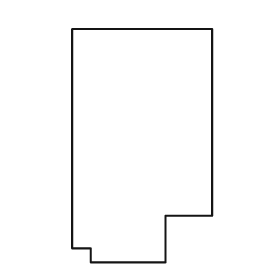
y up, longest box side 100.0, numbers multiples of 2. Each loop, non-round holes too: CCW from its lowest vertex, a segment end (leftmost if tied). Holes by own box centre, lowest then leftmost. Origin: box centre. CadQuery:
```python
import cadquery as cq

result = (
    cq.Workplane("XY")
    .moveTo(-22.0, -50.0)
    .lineTo(10.0, -50.0)
    .lineTo(10.0, -30.0)
    .lineTo(30.0, -30.0)
    .lineTo(30.0, 50.0)
    .lineTo(-30.0, 50.0)
    .lineTo(-30.0, -44.0)
    .lineTo(-22.0, -44.0)
    .close()
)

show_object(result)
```